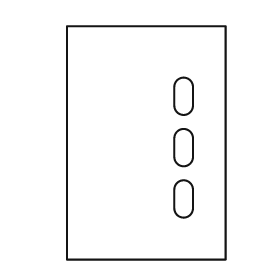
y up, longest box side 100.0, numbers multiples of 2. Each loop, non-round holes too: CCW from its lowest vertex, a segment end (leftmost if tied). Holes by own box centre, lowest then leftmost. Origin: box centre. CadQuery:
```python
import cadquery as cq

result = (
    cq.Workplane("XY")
    .moveTo(-34.0, -50.0)
    .lineTo(34.0, -50.0)
    .lineTo(34.0, 50.0)
    .lineTo(-34.0, 50.0)
    .close()
    .moveTo(12.0, -28.0)
    .threePointArc((16.0, -32.0), (20.0, -28.0))
    .lineTo(20.0, -20.0)
    .threePointArc((16.0, -16.0), (12.0, -20.0))
    .close()
    .moveTo(12.0, -6.0)
    .threePointArc((16.0, -10.0), (20.0, -6.0))
    .lineTo(20.0, 2.0)
    .threePointArc((16.0, 6.0), (12.0, 2.0))
    .close()
    .moveTo(12.0, 16.0)
    .threePointArc((16.0, 12.0), (20.0, 16.0))
    .lineTo(20.0, 24.0)
    .threePointArc((16.0, 28.0), (12.0, 24.0))
    .close()
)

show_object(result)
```